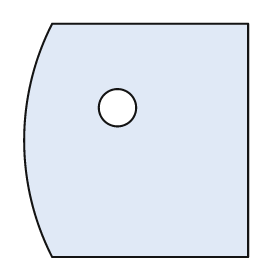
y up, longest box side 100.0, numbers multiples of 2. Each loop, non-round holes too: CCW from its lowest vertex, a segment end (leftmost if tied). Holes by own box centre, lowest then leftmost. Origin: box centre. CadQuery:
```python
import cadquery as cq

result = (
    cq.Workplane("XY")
    .moveTo(-36.0, -50.0)
    .lineTo(48.0, -50.0)
    .lineTo(48.0, 50.0)
    .lineTo(-36.0, 50.0)
    .threePointArc((-48.0, 0.0), (-36.0, -50.0))
    .close()
    .moveTo(-8.0, 14.0)
    .circle(8.0)
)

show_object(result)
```